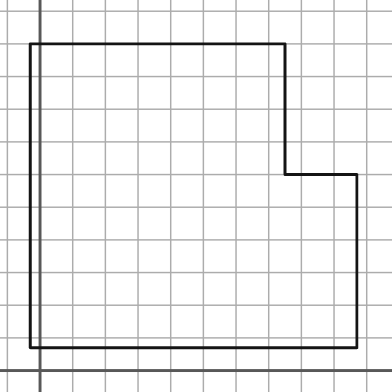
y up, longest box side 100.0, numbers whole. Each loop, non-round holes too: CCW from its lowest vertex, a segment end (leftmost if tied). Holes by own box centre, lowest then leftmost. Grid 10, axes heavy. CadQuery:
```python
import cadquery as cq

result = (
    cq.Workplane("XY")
    .moveTo(-3.0, 7.0)
    .lineTo(97.0, 7.0)
    .lineTo(97.0, 60.0)
    .lineTo(75.0, 60.0)
    .lineTo(75.0, 100.0)
    .lineTo(-3.0, 100.0)
    .close()
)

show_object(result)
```